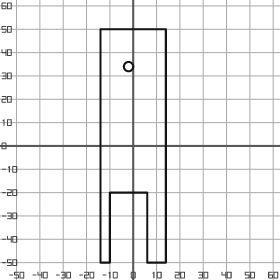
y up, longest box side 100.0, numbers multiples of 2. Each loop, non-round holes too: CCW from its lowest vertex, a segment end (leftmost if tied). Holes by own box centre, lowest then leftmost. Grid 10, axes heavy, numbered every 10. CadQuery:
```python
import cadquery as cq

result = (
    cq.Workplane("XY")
    .moveTo(-14.0, -50.0)
    .lineTo(-10.0, -50.0)
    .lineTo(-10.0, -20.0)
    .lineTo(6.0, -20.0)
    .lineTo(6.0, -50.0)
    .lineTo(14.0, -50.0)
    .lineTo(14.0, 50.0)
    .lineTo(-14.0, 50.0)
    .close()
    .moveTo(-2.0, 34.0)
    .circle(2.0)
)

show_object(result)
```